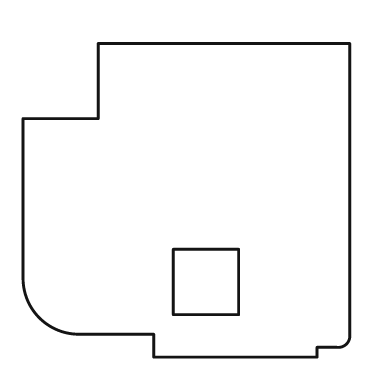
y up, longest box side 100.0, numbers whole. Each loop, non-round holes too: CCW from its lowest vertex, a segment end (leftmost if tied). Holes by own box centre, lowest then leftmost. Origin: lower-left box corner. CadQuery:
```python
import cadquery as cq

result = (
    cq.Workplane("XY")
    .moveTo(40.0, 0.0)
    .lineTo(90.0, 0.0)
    .lineTo(90.0, 3.0)
    .lineTo(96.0, 3.0)
    .threePointArc((99.0, 4.0), (100.0, 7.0))
    .lineTo(100.0, 96.0)
    .lineTo(23.0, 96.0)
    .lineTo(23.0, 73.0)
    .lineTo(0.0, 73.0)
    .lineTo(0.0, 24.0)
    .threePointArc((5.0, 12.0), (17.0, 7.0))
    .lineTo(40.0, 7.0)
    .close()
    .moveTo(46.0, 13.0)
    .lineTo(66.0, 13.0)
    .lineTo(66.0, 33.0)
    .lineTo(46.0, 33.0)
    .close()
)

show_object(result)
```